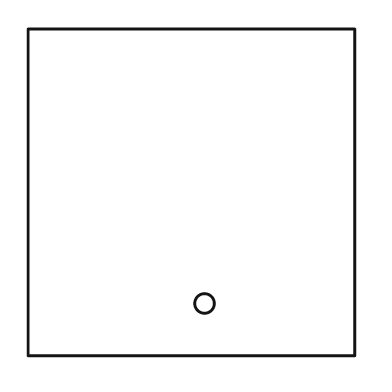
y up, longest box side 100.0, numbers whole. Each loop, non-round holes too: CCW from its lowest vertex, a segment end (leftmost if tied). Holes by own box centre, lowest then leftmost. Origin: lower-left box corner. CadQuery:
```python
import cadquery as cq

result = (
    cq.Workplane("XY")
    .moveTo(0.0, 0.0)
    .lineTo(100.0, 0.0)
    .lineTo(100.0, 100.0)
    .lineTo(0.0, 100.0)
    .close()
    .moveTo(54.0, 16.0)
    .circle(3.0)
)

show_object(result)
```